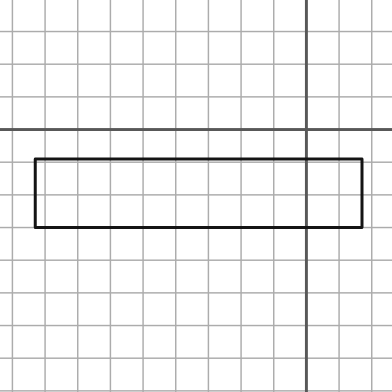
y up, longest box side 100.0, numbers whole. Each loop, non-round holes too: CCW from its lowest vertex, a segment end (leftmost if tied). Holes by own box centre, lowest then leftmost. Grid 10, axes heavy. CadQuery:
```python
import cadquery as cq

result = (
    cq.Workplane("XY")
    .moveTo(-83.0, -30.0)
    .lineTo(17.0, -30.0)
    .lineTo(17.0, -9.0)
    .lineTo(-83.0, -9.0)
    .close()
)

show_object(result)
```